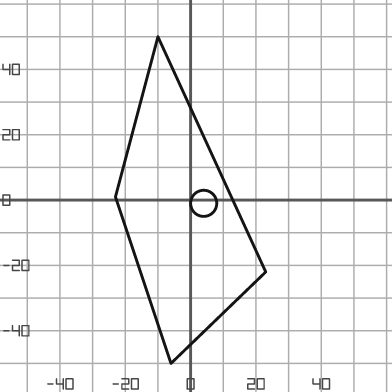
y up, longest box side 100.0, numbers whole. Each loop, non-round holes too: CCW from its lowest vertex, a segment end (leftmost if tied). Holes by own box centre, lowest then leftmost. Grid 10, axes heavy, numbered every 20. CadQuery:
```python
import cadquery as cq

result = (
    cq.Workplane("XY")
    .moveTo(-6.0, -50.0)
    .lineTo(23.0, -22.0)
    .lineTo(-10.0, 50.0)
    .lineTo(-23.0, 1.0)
    .close()
    .moveTo(4.0, -1.0)
    .circle(4.0)
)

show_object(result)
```